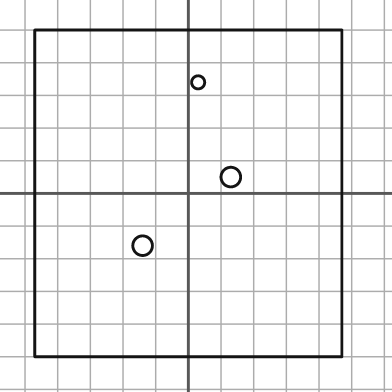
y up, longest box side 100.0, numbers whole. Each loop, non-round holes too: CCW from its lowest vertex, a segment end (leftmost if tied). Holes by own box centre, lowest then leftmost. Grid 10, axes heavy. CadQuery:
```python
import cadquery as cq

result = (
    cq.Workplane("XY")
    .moveTo(-47.0, -50.0)
    .lineTo(47.0, -50.0)
    .lineTo(47.0, 50.0)
    .lineTo(-47.0, 50.0)
    .close()
    .moveTo(-14.0, -16.0)
    .circle(3.0)
    .moveTo(13.0, 5.0)
    .circle(3.0)
    .moveTo(3.0, 34.0)
    .circle(2.0)
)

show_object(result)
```